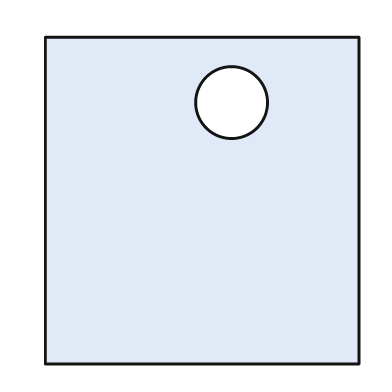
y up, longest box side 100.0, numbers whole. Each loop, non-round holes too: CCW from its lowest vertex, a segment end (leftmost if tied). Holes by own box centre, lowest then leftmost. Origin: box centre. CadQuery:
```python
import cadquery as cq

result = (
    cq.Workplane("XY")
    .moveTo(-48.0, -50.0)
    .lineTo(48.0, -50.0)
    .lineTo(48.0, 50.0)
    .lineTo(-48.0, 50.0)
    .close()
    .moveTo(9.0, 30.0)
    .circle(11.0)
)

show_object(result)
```